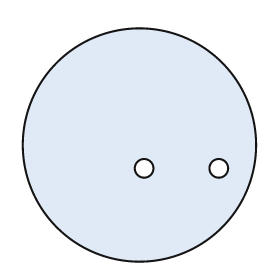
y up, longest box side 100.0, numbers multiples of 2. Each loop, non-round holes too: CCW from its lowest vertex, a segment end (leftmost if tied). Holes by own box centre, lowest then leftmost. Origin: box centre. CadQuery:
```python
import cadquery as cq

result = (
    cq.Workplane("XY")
    .moveTo(0.0, 0.0)
    .circle(50.0)
    .moveTo(2.0, -10.0)
    .circle(4.0)
    .moveTo(34.0, -10.0)
    .circle(4.0)
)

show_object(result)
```